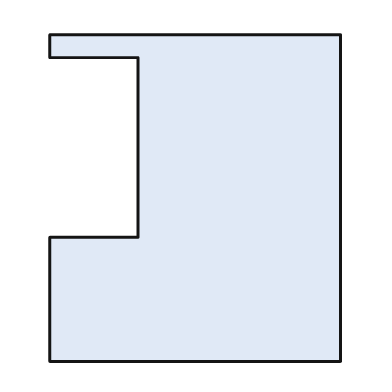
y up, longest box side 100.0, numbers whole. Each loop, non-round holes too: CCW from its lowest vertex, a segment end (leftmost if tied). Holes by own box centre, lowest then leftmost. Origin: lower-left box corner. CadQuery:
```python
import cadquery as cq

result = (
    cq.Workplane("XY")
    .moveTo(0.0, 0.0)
    .lineTo(89.0, 0.0)
    .lineTo(89.0, 100.0)
    .lineTo(0.0, 100.0)
    .lineTo(0.0, 93.0)
    .lineTo(27.0, 93.0)
    .lineTo(27.0, 38.0)
    .lineTo(0.0, 38.0)
    .close()
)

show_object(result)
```